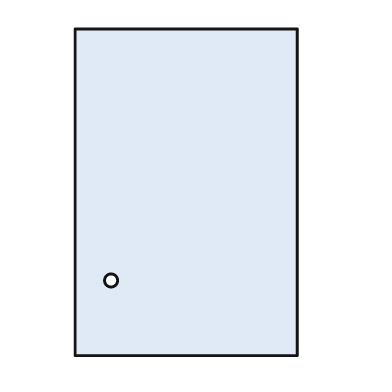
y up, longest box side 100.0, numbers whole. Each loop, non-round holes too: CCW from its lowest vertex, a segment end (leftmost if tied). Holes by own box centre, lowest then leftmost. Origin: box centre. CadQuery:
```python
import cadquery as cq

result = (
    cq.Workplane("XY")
    .moveTo(-34.0, -50.0)
    .lineTo(34.0, -50.0)
    .lineTo(34.0, 50.0)
    .lineTo(-34.0, 50.0)
    .close()
    .moveTo(-23.0, -27.0)
    .circle(2.0)
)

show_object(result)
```